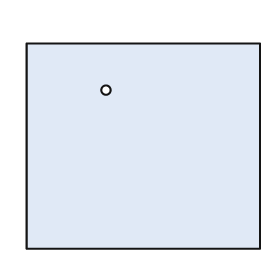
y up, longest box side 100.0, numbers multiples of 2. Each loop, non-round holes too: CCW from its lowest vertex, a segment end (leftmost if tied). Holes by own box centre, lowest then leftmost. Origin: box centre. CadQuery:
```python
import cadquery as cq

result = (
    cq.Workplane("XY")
    .moveTo(-50.0, -44.0)
    .lineTo(50.0, -44.0)
    .lineTo(50.0, 44.0)
    .lineTo(-50.0, 44.0)
    .close()
    .moveTo(-16.0, 24.0)
    .circle(2.0)
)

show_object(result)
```